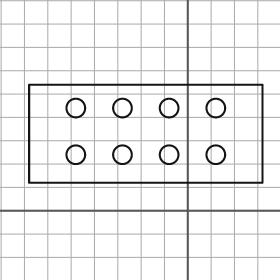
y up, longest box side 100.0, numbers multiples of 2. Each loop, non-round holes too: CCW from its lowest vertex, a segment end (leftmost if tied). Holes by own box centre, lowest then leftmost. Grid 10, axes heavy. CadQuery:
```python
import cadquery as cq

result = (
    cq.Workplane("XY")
    .moveTo(-68.0, 12.0)
    .lineTo(32.0, 12.0)
    .lineTo(32.0, 54.0)
    .lineTo(-68.0, 54.0)
    .close()
    .moveTo(-48.0, 24.0)
    .circle(4.0)
    .moveTo(-28.0, 24.0)
    .circle(4.0)
    .moveTo(-8.0, 24.0)
    .circle(4.0)
    .moveTo(12.0, 24.0)
    .circle(4.0)
    .moveTo(-48.0, 44.0)
    .circle(4.0)
    .moveTo(-28.0, 44.0)
    .circle(4.0)
    .moveTo(-8.0, 44.0)
    .circle(4.0)
    .moveTo(12.0, 44.0)
    .circle(4.0)
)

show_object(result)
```